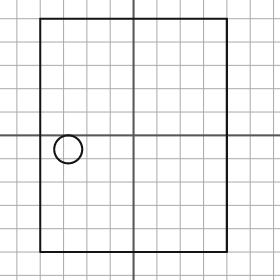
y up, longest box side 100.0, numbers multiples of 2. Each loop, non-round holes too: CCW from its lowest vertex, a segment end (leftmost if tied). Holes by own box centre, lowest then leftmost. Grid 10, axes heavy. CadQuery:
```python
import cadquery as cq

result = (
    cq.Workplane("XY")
    .moveTo(-40.0, -50.0)
    .lineTo(40.0, -50.0)
    .lineTo(40.0, 50.0)
    .lineTo(-40.0, 50.0)
    .close()
    .moveTo(-28.0, -6.0)
    .circle(6.0)
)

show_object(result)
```